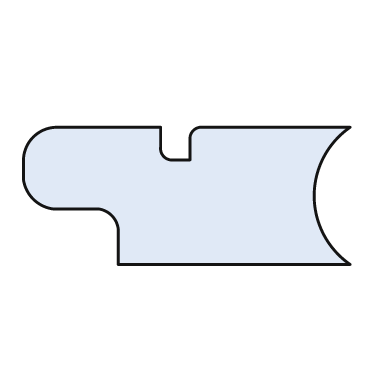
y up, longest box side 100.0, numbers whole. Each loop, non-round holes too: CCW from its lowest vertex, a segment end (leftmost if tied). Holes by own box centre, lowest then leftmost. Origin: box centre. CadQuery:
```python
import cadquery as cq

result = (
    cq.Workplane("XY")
    .moveTo(-21.0, -21.0)
    .lineTo(50.0, -21.0)
    .threePointArc((39.0, 0.0), (50.0, 21.0))
    .lineTo(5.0, 21.0)
    .threePointArc((2.0, 20.0), (1.0, 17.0))
    .lineTo(1.0, 11.0)
    .lineTo(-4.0, 11.0)
    .threePointArc((-7.0, 12.0), (-8.0, 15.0))
    .lineTo(-8.0, 21.0)
    .lineTo(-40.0, 21.0)
    .threePointArc((-47.0, 18.0), (-50.0, 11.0))
    .lineTo(-50.0, 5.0)
    .threePointArc((-47.0, -1.0), (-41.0, -4.0))
    .lineTo(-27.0, -4.0)
    .threePointArc((-23.0, -6.0), (-21.0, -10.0))
    .close()
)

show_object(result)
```